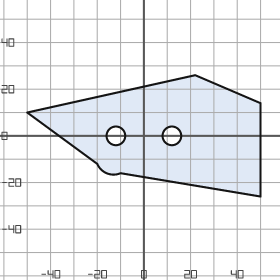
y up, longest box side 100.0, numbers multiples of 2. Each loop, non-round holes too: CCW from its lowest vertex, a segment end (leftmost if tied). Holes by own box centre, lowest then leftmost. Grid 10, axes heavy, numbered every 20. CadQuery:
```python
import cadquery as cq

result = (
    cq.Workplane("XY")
    .moveTo(50.0, -26.0)
    .lineTo(50.0, 14.0)
    .lineTo(22.0, 26.0)
    .lineTo(-50.0, 10.0)
    .lineTo(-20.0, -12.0)
    .threePointArc((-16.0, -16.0), (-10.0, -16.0))
    .close()
    .moveTo(-12.0, 0.0)
    .circle(4.0)
    .moveTo(12.0, 0.0)
    .circle(4.0)
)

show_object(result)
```